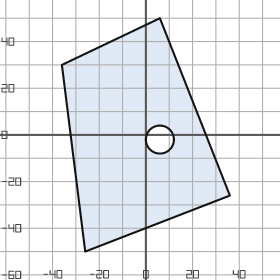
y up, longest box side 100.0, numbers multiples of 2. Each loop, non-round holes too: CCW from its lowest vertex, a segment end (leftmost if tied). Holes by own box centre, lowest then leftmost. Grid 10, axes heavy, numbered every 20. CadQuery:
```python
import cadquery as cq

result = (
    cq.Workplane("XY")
    .moveTo(-26.0, -50.0)
    .lineTo(36.0, -26.0)
    .lineTo(6.0, 50.0)
    .lineTo(-36.0, 30.0)
    .close()
    .moveTo(6.0, -2.0)
    .circle(6.0)
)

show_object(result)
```